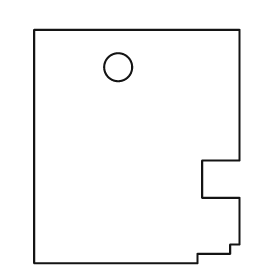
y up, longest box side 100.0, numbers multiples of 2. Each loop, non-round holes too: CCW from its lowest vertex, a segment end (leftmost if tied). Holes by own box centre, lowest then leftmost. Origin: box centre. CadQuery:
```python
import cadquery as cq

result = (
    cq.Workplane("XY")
    .moveTo(-44.0, -50.0)
    .lineTo(26.0, -50.0)
    .lineTo(26.0, -46.0)
    .lineTo(40.0, -46.0)
    .lineTo(40.0, -42.0)
    .lineTo(44.0, -42.0)
    .lineTo(44.0, -22.0)
    .lineTo(28.0, -22.0)
    .lineTo(28.0, -6.0)
    .lineTo(44.0, -6.0)
    .lineTo(44.0, 50.0)
    .lineTo(-44.0, 50.0)
    .close()
    .moveTo(-8.0, 34.0)
    .circle(6.0)
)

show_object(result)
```